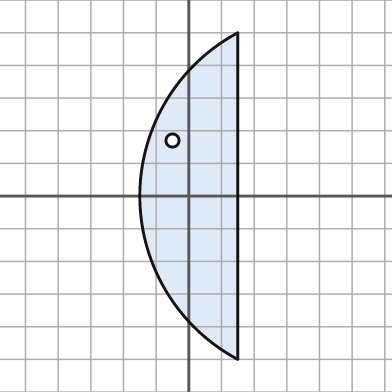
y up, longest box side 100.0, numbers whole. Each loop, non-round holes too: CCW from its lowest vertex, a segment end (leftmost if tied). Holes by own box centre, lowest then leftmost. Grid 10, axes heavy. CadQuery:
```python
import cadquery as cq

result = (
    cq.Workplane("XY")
    .moveTo(15.0, -50.0)
    .lineTo(15.0, 50.0)
    .threePointArc((-15.0, 0.0), (15.0, -50.0))
    .close()
    .moveTo(-5.0, 17.0)
    .circle(2.0)
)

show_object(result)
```